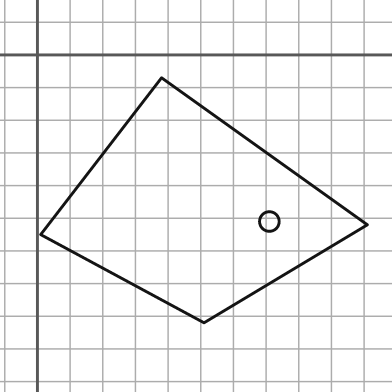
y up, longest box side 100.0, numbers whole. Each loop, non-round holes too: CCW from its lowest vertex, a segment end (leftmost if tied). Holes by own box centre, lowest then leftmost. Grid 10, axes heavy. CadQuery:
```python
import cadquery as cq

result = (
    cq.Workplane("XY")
    .moveTo(51.0, -82.0)
    .lineTo(101.0, -52.0)
    .lineTo(38.0, -7.0)
    .lineTo(1.0, -55.0)
    .close()
    .moveTo(71.0, -51.0)
    .circle(3.0)
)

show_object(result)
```